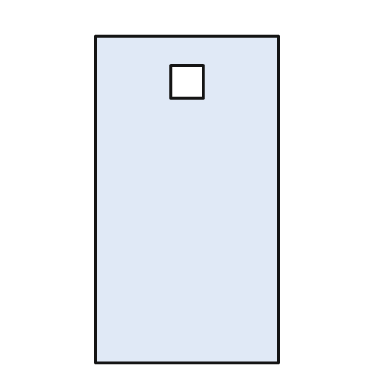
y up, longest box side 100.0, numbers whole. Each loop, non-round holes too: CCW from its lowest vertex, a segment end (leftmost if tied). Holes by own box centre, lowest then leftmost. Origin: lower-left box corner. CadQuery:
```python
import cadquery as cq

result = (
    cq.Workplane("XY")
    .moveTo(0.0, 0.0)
    .lineTo(56.0, 0.0)
    .lineTo(56.0, 100.0)
    .lineTo(0.0, 100.0)
    .close()
    .moveTo(23.0, 81.0)
    .lineTo(33.0, 81.0)
    .lineTo(33.0, 91.0)
    .lineTo(23.0, 91.0)
    .close()
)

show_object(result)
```